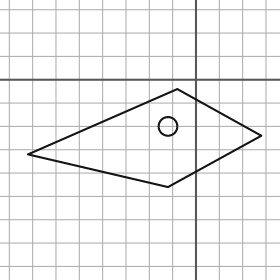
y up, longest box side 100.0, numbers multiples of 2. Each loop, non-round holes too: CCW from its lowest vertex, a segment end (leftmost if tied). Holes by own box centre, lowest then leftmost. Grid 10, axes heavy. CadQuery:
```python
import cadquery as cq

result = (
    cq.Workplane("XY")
    .moveTo(-12.0, -46.0)
    .lineTo(28.0, -24.0)
    .lineTo(-8.0, -4.0)
    .lineTo(-72.0, -32.0)
    .close()
    .moveTo(-12.0, -20.0)
    .circle(4.0)
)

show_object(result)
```